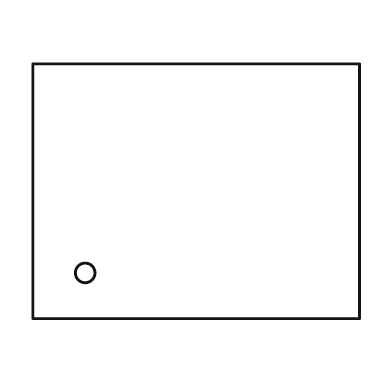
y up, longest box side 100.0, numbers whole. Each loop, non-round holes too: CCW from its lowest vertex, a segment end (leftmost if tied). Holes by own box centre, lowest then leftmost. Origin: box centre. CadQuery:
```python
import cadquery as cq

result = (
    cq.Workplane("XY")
    .moveTo(-50.0, -39.0)
    .lineTo(50.0, -39.0)
    .lineTo(50.0, 39.0)
    .lineTo(-50.0, 39.0)
    .close()
    .moveTo(-34.0, -25.0)
    .circle(3.0)
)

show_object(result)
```